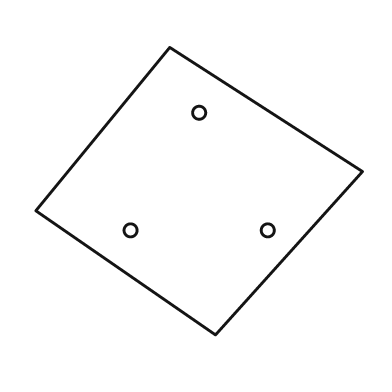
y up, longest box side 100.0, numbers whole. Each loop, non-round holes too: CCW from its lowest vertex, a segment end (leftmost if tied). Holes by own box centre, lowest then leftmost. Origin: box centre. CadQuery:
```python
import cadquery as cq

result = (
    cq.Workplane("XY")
    .moveTo(5.0, -44.0)
    .lineTo(50.0, 6.0)
    .lineTo(-9.0, 44.0)
    .lineTo(-50.0, -6.0)
    .close()
    .moveTo(-21.0, -12.0)
    .circle(2.0)
    .moveTo(21.0, -12.0)
    .circle(2.0)
    .moveTo(0.0, 24.0)
    .circle(2.0)
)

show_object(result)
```